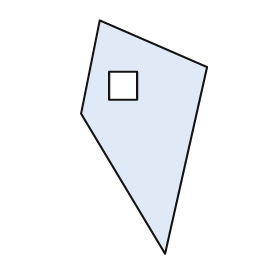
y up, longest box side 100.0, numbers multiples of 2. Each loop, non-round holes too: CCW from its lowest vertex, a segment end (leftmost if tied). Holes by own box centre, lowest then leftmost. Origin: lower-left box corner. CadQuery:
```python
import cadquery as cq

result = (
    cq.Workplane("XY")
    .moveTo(36.0, 0.0)
    .lineTo(54.0, 80.0)
    .lineTo(8.0, 100.0)
    .lineTo(0.0, 60.0)
    .close()
    .moveTo(12.0, 66.0)
    .lineTo(24.0, 66.0)
    .lineTo(24.0, 78.0)
    .lineTo(12.0, 78.0)
    .close()
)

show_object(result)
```